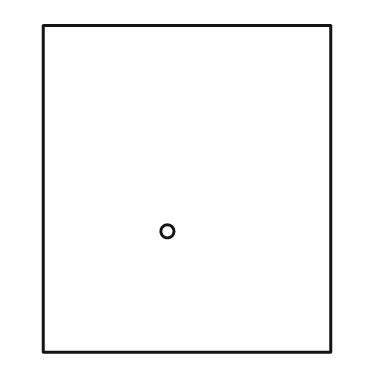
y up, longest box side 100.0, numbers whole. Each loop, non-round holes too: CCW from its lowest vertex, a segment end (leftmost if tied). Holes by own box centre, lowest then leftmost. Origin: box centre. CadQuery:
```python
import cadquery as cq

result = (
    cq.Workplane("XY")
    .moveTo(-44.0, -50.0)
    .lineTo(44.0, -50.0)
    .lineTo(44.0, 50.0)
    .lineTo(-44.0, 50.0)
    .close()
    .moveTo(-6.0, -13.0)
    .circle(2.0)
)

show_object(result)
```